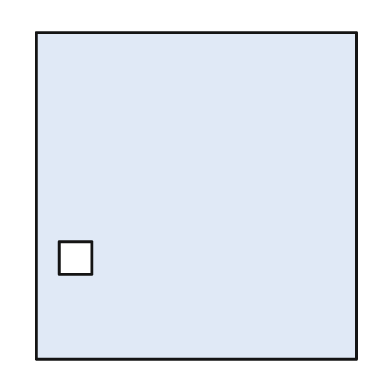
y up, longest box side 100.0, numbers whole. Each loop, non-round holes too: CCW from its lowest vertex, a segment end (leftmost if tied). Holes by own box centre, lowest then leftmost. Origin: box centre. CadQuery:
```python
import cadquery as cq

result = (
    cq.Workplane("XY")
    .moveTo(-49.0, -50.0)
    .lineTo(49.0, -50.0)
    .lineTo(49.0, 50.0)
    .lineTo(-49.0, 50.0)
    .close()
    .moveTo(-42.0, -24.0)
    .lineTo(-32.0, -24.0)
    .lineTo(-32.0, -14.0)
    .lineTo(-42.0, -14.0)
    .close()
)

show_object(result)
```